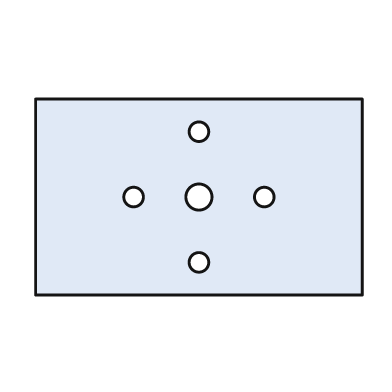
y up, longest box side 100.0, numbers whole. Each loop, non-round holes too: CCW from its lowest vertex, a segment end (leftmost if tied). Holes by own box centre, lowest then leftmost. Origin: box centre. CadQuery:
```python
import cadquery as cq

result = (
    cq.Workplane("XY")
    .moveTo(-50.0, -30.0)
    .lineTo(50.0, -30.0)
    .lineTo(50.0, 30.0)
    .lineTo(-50.0, 30.0)
    .close()
    .moveTo(0.0, -20.0)
    .circle(3.0)
    .moveTo(-20.0, 0.0)
    .circle(3.0)
    .moveTo(0.0, 0.0)
    .circle(4.0)
    .moveTo(20.0, 0.0)
    .circle(3.0)
    .moveTo(0.0, 20.0)
    .circle(3.0)
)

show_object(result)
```